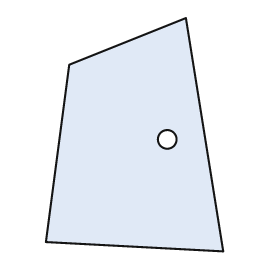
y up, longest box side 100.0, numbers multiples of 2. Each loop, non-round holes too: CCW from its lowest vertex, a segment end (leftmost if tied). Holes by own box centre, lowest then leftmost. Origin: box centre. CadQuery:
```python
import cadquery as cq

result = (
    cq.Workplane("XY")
    .moveTo(38.0, -50.0)
    .lineTo(22.0, 50.0)
    .lineTo(-28.0, 30.0)
    .lineTo(-38.0, -46.0)
    .close()
    .moveTo(14.0, -2.0)
    .circle(4.0)
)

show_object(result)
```